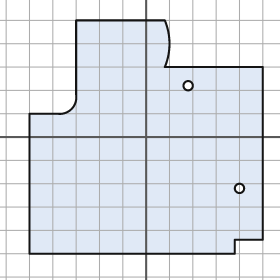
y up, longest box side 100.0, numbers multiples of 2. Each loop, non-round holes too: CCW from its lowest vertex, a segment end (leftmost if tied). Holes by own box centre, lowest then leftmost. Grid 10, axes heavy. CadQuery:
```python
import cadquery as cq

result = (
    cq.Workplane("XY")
    .moveTo(-50.0, -50.0)
    .lineTo(38.0, -50.0)
    .lineTo(38.0, -44.0)
    .lineTo(50.0, -44.0)
    .lineTo(50.0, 30.0)
    .lineTo(8.0, 30.0)
    .threePointArc((10.0, 40.0), (8.0, 50.0))
    .lineTo(-30.0, 50.0)
    .lineTo(-30.0, 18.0)
    .threePointArc((-32.0, 12.0), (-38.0, 10.0))
    .lineTo(-50.0, 10.0)
    .close()
    .moveTo(40.0, -22.0)
    .circle(2.0)
    .moveTo(18.0, 22.0)
    .circle(2.0)
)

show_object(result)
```